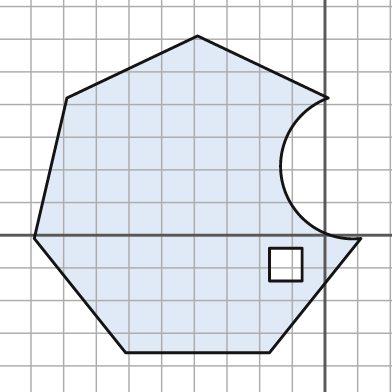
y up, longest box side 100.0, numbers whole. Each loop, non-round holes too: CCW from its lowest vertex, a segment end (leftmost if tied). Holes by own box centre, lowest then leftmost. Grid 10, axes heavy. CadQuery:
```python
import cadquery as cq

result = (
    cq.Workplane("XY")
    .moveTo(-61.0, -36.0)
    .lineTo(-17.0, -36.0)
    .lineTo(11.0, -1.0)
    .threePointArc((-13.0, 16.0), (1.0, 42.0))
    .lineTo(-39.0, 61.0)
    .lineTo(-79.0, 42.0)
    .lineTo(-89.0, -1.0)
    .close()
    .moveTo(-17.0, -14.0)
    .lineTo(-7.0, -14.0)
    .lineTo(-7.0, -4.0)
    .lineTo(-17.0, -4.0)
    .close()
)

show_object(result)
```